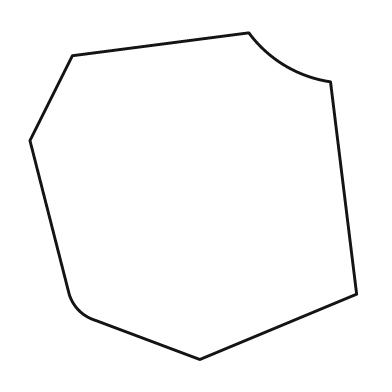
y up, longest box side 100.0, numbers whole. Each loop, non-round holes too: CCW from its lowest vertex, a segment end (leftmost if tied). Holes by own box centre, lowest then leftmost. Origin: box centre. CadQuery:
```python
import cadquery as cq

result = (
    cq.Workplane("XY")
    .moveTo(2.0, -50.0)
    .lineTo(50.0, -30.0)
    .lineTo(42.0, 35.0)
    .threePointArc((28.0, 40.0), (17.0, 50.0))
    .lineTo(-37.0, 43.0)
    .lineTo(-50.0, 17.0)
    .lineTo(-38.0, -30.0)
    .threePointArc((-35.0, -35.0), (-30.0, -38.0))
    .close()
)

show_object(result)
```